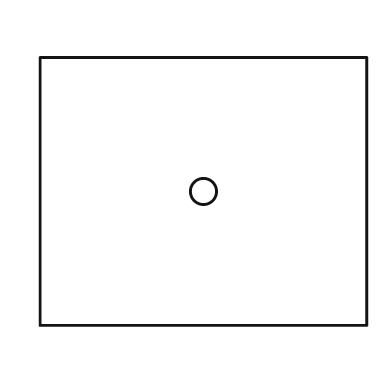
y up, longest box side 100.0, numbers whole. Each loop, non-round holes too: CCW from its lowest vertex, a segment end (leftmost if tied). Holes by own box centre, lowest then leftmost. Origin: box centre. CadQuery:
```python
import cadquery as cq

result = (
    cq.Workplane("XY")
    .moveTo(-50.0, -41.0)
    .lineTo(50.0, -41.0)
    .lineTo(50.0, 41.0)
    .lineTo(-50.0, 41.0)
    .close()
    .moveTo(0.0, 0.0)
    .circle(4.0)
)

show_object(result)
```